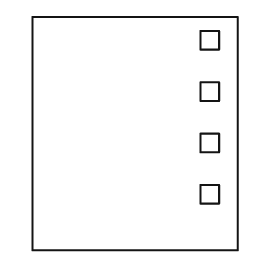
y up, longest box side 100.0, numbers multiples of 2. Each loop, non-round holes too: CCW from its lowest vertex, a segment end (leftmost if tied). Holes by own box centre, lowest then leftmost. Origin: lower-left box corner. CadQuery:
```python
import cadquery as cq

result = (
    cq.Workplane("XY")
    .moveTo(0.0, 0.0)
    .lineTo(88.0, 0.0)
    .lineTo(88.0, 100.0)
    .lineTo(0.0, 100.0)
    .close()
    .moveTo(72.0, 20.0)
    .lineTo(80.0, 20.0)
    .lineTo(80.0, 28.0)
    .lineTo(72.0, 28.0)
    .close()
    .moveTo(72.0, 42.0)
    .lineTo(80.0, 42.0)
    .lineTo(80.0, 50.0)
    .lineTo(72.0, 50.0)
    .close()
    .moveTo(72.0, 64.0)
    .lineTo(80.0, 64.0)
    .lineTo(80.0, 72.0)
    .lineTo(72.0, 72.0)
    .close()
    .moveTo(72.0, 86.0)
    .lineTo(80.0, 86.0)
    .lineTo(80.0, 94.0)
    .lineTo(72.0, 94.0)
    .close()
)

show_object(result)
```